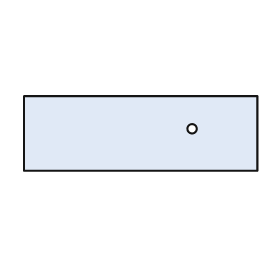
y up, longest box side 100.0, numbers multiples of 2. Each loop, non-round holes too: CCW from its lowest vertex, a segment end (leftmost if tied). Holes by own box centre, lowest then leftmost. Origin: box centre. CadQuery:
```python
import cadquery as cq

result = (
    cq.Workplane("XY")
    .moveTo(-50.0, -16.0)
    .lineTo(50.0, -16.0)
    .lineTo(50.0, 16.0)
    .lineTo(-50.0, 16.0)
    .close()
    .moveTo(22.0, 2.0)
    .circle(2.0)
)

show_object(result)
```